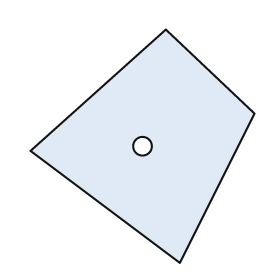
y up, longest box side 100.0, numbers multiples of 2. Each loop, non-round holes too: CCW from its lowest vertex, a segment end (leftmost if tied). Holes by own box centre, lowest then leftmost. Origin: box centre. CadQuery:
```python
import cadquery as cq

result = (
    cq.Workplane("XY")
    .moveTo(16.0, -50.0)
    .lineTo(48.0, 14.0)
    .lineTo(10.0, 50.0)
    .lineTo(-48.0, -2.0)
    .close()
    .moveTo(0.0, 0.0)
    .circle(4.0)
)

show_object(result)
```